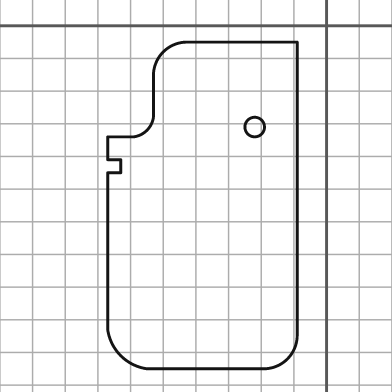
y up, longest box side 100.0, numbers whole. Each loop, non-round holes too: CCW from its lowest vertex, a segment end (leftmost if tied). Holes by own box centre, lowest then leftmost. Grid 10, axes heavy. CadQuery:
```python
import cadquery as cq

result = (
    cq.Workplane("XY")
    .moveTo(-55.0, -105.0)
    .lineTo(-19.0, -105.0)
    .threePointArc((-12.0, -102.0), (-9.0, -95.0))
    .lineTo(-9.0, -5.0)
    .lineTo(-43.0, -5.0)
    .threePointArc((-50.0, -8.0), (-53.0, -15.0))
    .lineTo(-53.0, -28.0)
    .threePointArc((-55.0, -32.0), (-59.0, -34.0))
    .lineTo(-67.0, -34.0)
    .lineTo(-67.0, -41.0)
    .lineTo(-63.0, -41.0)
    .lineTo(-63.0, -45.0)
    .lineTo(-67.0, -45.0)
    .lineTo(-67.0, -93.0)
    .threePointArc((-63.0, -101.0), (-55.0, -105.0))
    .close()
    .moveTo(-22.0, -31.0)
    .circle(3.0)
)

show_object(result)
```